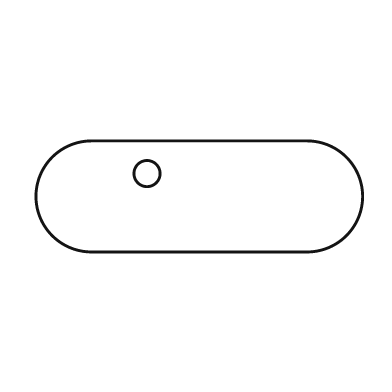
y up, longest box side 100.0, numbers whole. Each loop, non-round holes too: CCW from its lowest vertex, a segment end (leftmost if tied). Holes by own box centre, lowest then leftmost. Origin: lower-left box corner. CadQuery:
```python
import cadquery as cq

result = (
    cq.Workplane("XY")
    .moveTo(17.0, 0.0)
    .lineTo(83.0, 0.0)
    .threePointArc((100.0, 17.0), (83.0, 34.0))
    .lineTo(17.0, 34.0)
    .threePointArc((0.0, 17.0), (17.0, 0.0))
    .close()
    .moveTo(34.0, 24.0)
    .circle(4.0)
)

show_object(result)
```